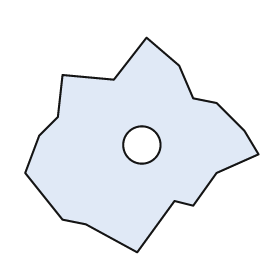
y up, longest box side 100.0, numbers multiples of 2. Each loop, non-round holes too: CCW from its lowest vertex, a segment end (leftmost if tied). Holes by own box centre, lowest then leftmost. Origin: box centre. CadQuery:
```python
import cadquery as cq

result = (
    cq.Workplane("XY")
    .moveTo(-2.0, -46.0)
    .lineTo(14.0, -24.0)
    .lineTo(22.0, -26.0)
    .lineTo(32.0, -12.0)
    .lineTo(50.0, -4.0)
    .lineTo(44.0, 6.0)
    .lineTo(32.0, 18.0)
    .lineTo(22.0, 20.0)
    .lineTo(16.0, 34.0)
    .lineTo(2.0, 46.0)
    .lineTo(-12.0, 28.0)
    .lineTo(-34.0, 30.0)
    .lineTo(-36.0, 12.0)
    .lineTo(-44.0, 4.0)
    .lineTo(-50.0, -12.0)
    .lineTo(-34.0, -32.0)
    .lineTo(-24.0, -34.0)
    .close()
    .moveTo(0.0, 0.0)
    .circle(8.0)
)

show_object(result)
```